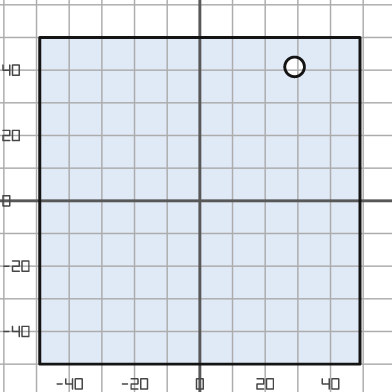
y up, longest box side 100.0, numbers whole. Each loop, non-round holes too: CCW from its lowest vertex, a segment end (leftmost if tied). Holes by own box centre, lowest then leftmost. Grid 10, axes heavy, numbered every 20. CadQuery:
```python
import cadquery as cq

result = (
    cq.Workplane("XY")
    .moveTo(-49.0, -50.0)
    .lineTo(49.0, -50.0)
    .lineTo(49.0, 50.0)
    .lineTo(-49.0, 50.0)
    .close()
    .moveTo(29.0, 41.0)
    .circle(3.0)
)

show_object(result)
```